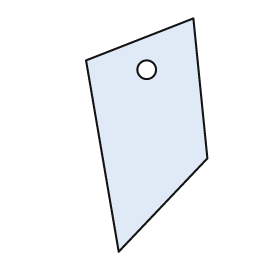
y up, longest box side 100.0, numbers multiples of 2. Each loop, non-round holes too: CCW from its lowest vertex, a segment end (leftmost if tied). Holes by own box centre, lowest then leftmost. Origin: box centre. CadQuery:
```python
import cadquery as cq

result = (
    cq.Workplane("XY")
    .moveTo(-12.0, -50.0)
    .lineTo(26.0, -10.0)
    .lineTo(20.0, 50.0)
    .lineTo(-26.0, 32.0)
    .close()
    .moveTo(0.0, 28.0)
    .circle(4.0)
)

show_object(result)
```